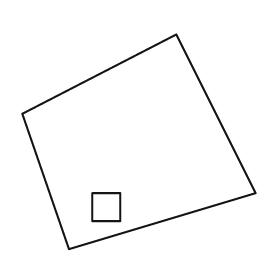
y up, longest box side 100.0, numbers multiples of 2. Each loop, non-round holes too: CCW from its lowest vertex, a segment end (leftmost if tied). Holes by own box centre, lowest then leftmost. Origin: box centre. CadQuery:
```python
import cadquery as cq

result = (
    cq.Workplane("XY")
    .moveTo(-30.0, -46.0)
    .lineTo(50.0, -22.0)
    .lineTo(16.0, 46.0)
    .lineTo(-50.0, 12.0)
    .close()
    .moveTo(-20.0, -34.0)
    .lineTo(-8.0, -34.0)
    .lineTo(-8.0, -22.0)
    .lineTo(-20.0, -22.0)
    .close()
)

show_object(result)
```